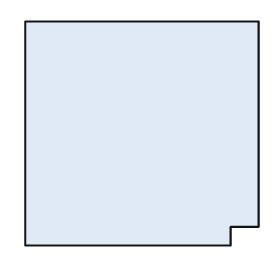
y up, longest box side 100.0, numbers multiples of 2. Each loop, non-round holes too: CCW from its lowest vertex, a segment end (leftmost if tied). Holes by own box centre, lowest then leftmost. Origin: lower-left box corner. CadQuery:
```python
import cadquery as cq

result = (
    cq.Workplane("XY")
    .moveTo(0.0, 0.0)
    .lineTo(88.0, 0.0)
    .lineTo(88.0, 8.0)
    .lineTo(100.0, 8.0)
    .lineTo(100.0, 96.0)
    .lineTo(0.0, 96.0)
    .close()
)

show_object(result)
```